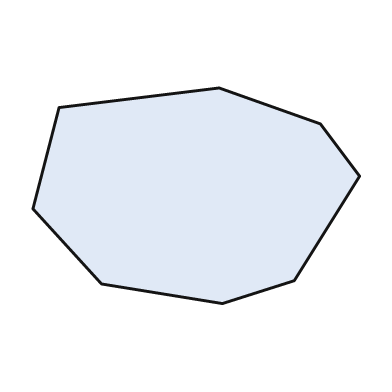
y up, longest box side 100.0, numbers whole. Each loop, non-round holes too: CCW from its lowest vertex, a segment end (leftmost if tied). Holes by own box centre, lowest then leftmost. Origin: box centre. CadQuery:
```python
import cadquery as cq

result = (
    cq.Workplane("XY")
    .moveTo(8.0, -33.0)
    .lineTo(30.0, -26.0)
    .lineTo(50.0, 6.0)
    .lineTo(38.0, 22.0)
    .lineTo(7.0, 33.0)
    .lineTo(-42.0, 27.0)
    .lineTo(-50.0, -4.0)
    .lineTo(-29.0, -27.0)
    .close()
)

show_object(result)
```